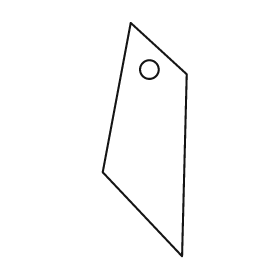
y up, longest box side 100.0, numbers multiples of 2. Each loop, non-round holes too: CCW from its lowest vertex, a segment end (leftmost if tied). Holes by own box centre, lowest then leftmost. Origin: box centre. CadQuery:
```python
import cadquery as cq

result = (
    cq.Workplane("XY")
    .moveTo(16.0, -50.0)
    .lineTo(18.0, 28.0)
    .lineTo(-6.0, 50.0)
    .lineTo(-18.0, -14.0)
    .close()
    .moveTo(2.0, 30.0)
    .circle(4.0)
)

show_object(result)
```